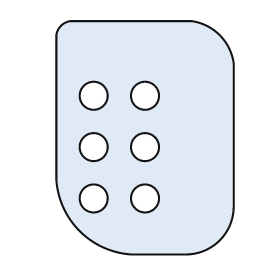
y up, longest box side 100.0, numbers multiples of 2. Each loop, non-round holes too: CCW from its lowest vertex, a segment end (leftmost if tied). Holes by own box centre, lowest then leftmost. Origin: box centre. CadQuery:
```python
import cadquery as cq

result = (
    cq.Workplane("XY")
    .moveTo(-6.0, -50.0)
    .lineTo(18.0, -50.0)
    .threePointArc((32.0, -44.0), (38.0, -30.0))
    .lineTo(38.0, 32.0)
    .threePointArc((32.0, 44.0), (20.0, 50.0))
    .lineTo(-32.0, 50.0)
    .threePointArc((-36.0, 48.0), (-38.0, 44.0))
    .lineTo(-38.0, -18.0)
    .threePointArc((-28.0, -40.0), (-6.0, -50.0))
    .close()
    .moveTo(-22.0, -26.0)
    .circle(6.0)
    .moveTo(0.0, -26.0)
    .circle(6.0)
    .moveTo(-22.0, -4.0)
    .circle(6.0)
    .moveTo(0.0, -4.0)
    .circle(6.0)
    .moveTo(-22.0, 18.0)
    .circle(6.0)
    .moveTo(0.0, 18.0)
    .circle(6.0)
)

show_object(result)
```